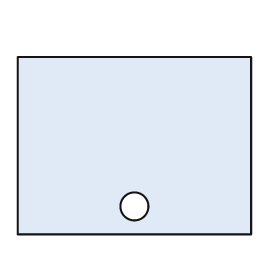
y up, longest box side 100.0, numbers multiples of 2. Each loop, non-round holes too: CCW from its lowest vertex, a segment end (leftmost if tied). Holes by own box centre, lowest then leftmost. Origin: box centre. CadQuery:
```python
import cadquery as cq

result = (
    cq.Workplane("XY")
    .moveTo(-50.0, -38.0)
    .lineTo(50.0, -38.0)
    .lineTo(50.0, 38.0)
    .lineTo(-50.0, 38.0)
    .close()
    .moveTo(0.0, -26.0)
    .circle(6.0)
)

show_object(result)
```